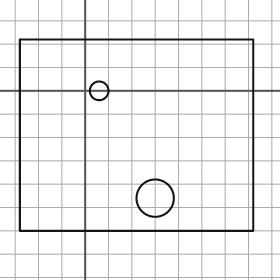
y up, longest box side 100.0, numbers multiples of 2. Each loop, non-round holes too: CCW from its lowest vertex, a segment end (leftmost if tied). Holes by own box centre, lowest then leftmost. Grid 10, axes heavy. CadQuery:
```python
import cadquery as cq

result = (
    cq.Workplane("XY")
    .moveTo(-28.0, -60.0)
    .lineTo(72.0, -60.0)
    .lineTo(72.0, 22.0)
    .lineTo(-28.0, 22.0)
    .close()
    .moveTo(30.0, -46.0)
    .circle(8.0)
    .moveTo(6.0, 0.0)
    .circle(4.0)
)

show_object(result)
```